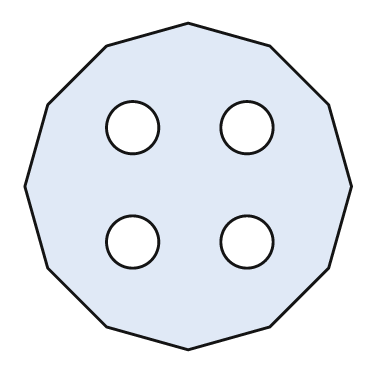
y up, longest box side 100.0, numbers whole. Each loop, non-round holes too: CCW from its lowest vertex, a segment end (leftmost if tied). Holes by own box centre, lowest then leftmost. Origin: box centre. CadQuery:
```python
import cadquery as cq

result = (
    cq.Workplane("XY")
    .moveTo(0.0, -50.0)
    .lineTo(25.0, -43.0)
    .lineTo(43.0, -25.0)
    .lineTo(50.0, 0.0)
    .lineTo(43.0, 25.0)
    .lineTo(25.0, 43.0)
    .lineTo(0.0, 50.0)
    .lineTo(-25.0, 43.0)
    .lineTo(-43.0, 25.0)
    .lineTo(-50.0, 0.0)
    .lineTo(-43.0, -25.0)
    .lineTo(-25.0, -43.0)
    .close()
    .moveTo(-17.0, -17.0)
    .circle(8.0)
    .moveTo(18.0, -17.0)
    .circle(8.0)
    .moveTo(-17.0, 18.0)
    .circle(8.0)
    .moveTo(18.0, 18.0)
    .circle(8.0)
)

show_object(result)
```